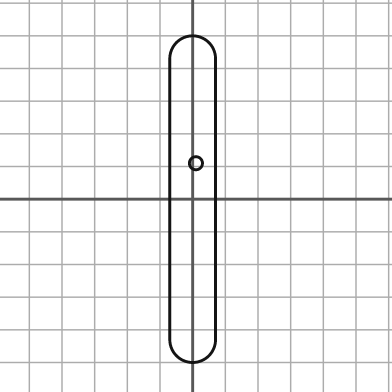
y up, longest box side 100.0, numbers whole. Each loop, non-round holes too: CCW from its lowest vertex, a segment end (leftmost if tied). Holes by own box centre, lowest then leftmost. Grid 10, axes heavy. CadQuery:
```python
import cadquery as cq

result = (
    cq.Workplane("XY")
    .moveTo(-7.0, -43.0)
    .threePointArc((0.0, -50.0), (7.0, -43.0))
    .lineTo(7.0, 43.0)
    .threePointArc((0.0, 50.0), (-7.0, 43.0))
    .close()
    .moveTo(1.0, 11.0)
    .circle(2.0)
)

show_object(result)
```